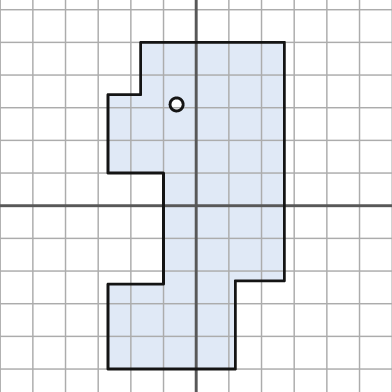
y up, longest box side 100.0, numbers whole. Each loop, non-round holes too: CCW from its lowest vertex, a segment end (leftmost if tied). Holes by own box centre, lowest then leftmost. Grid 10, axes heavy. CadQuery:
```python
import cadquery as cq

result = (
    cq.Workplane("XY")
    .moveTo(-27.0, -50.0)
    .lineTo(12.0, -50.0)
    .lineTo(12.0, -23.0)
    .lineTo(27.0, -23.0)
    .lineTo(27.0, 50.0)
    .lineTo(-17.0, 50.0)
    .lineTo(-17.0, 34.0)
    .lineTo(-27.0, 34.0)
    .lineTo(-27.0, 10.0)
    .lineTo(-10.0, 10.0)
    .lineTo(-10.0, -24.0)
    .lineTo(-27.0, -24.0)
    .close()
    .moveTo(-6.0, 31.0)
    .circle(2.0)
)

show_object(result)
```